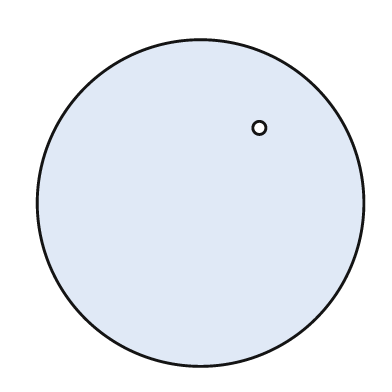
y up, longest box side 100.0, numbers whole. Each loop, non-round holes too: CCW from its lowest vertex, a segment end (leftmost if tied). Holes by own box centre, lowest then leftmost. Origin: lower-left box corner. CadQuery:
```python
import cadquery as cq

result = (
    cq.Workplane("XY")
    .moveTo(50.0, 50.0)
    .circle(50.0)
    .moveTo(68.0, 73.0)
    .circle(2.0)
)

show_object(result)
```